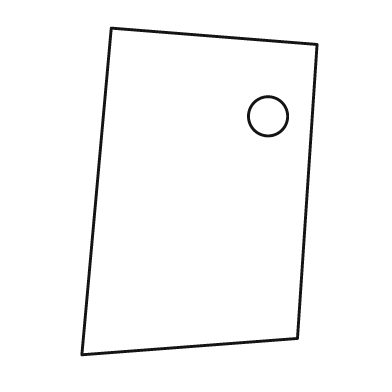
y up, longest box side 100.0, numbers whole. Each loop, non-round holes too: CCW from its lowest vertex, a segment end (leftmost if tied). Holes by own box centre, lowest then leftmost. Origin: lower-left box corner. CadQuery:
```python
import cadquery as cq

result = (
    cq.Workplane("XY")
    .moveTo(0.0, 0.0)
    .lineTo(66.0, 5.0)
    .lineTo(72.0, 95.0)
    .lineTo(9.0, 100.0)
    .close()
    .moveTo(57.0, 73.0)
    .circle(6.0)
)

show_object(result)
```